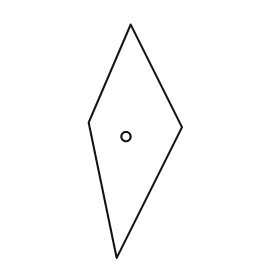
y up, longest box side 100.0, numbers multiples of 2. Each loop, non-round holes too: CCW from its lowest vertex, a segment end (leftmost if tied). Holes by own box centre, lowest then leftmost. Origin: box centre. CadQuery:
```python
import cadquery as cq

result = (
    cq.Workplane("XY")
    .moveTo(-8.0, -50.0)
    .lineTo(20.0, 6.0)
    .lineTo(-2.0, 50.0)
    .lineTo(-20.0, 8.0)
    .close()
    .moveTo(-4.0, 2.0)
    .circle(2.0)
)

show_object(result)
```